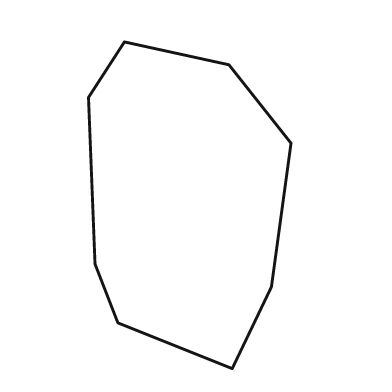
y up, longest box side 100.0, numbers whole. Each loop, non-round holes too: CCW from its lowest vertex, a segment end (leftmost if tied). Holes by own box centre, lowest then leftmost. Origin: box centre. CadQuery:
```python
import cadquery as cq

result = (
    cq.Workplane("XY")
    .moveTo(13.0, -50.0)
    .lineTo(25.0, -25.0)
    .lineTo(31.0, 19.0)
    .lineTo(12.0, 43.0)
    .lineTo(-20.0, 50.0)
    .lineTo(-31.0, 33.0)
    .lineTo(-29.0, -18.0)
    .lineTo(-22.0, -36.0)
    .close()
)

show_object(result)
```